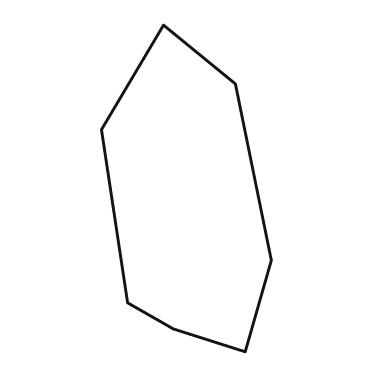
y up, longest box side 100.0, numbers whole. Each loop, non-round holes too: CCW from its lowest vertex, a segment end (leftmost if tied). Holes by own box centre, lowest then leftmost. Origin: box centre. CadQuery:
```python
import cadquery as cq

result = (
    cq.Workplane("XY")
    .moveTo(18.0, -50.0)
    .lineTo(26.0, -22.0)
    .lineTo(15.0, 32.0)
    .lineTo(-7.0, 50.0)
    .lineTo(-26.0, 18.0)
    .lineTo(-18.0, -35.0)
    .lineTo(-4.0, -43.0)
    .close()
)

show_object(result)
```